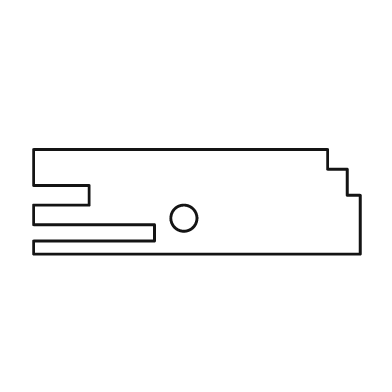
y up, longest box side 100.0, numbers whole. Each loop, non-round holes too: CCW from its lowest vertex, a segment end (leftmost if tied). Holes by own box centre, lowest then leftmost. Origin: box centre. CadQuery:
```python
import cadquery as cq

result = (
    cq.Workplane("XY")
    .moveTo(-50.0, -16.0)
    .lineTo(50.0, -16.0)
    .lineTo(50.0, 2.0)
    .lineTo(46.0, 2.0)
    .lineTo(46.0, 10.0)
    .lineTo(40.0, 10.0)
    .lineTo(40.0, 16.0)
    .lineTo(-50.0, 16.0)
    .lineTo(-50.0, 5.0)
    .lineTo(-33.0, 5.0)
    .lineTo(-33.0, -1.0)
    .lineTo(-50.0, -1.0)
    .lineTo(-50.0, -7.0)
    .lineTo(-13.0, -7.0)
    .lineTo(-13.0, -12.0)
    .lineTo(-50.0, -12.0)
    .close()
    .moveTo(-4.0, -5.0)
    .circle(4.0)
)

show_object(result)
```